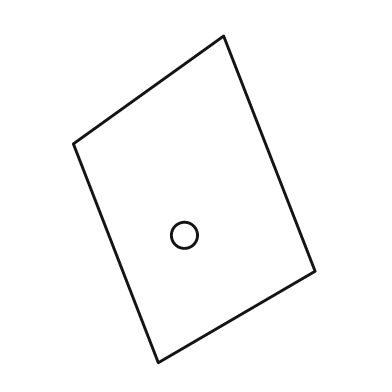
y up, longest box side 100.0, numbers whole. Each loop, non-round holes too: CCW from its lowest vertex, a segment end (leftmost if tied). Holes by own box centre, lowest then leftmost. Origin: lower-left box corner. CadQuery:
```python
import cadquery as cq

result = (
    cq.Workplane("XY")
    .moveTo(26.0, 0.0)
    .lineTo(74.0, 28.0)
    .lineTo(46.0, 100.0)
    .lineTo(0.0, 67.0)
    .close()
    .moveTo(34.0, 39.0)
    .circle(4.0)
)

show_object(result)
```